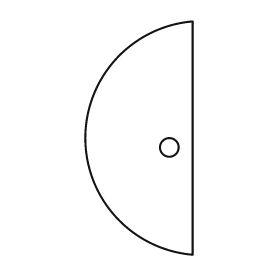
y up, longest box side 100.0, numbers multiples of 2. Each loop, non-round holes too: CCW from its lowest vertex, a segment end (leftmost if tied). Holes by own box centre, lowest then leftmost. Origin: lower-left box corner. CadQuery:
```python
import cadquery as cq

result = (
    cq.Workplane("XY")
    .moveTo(46.0, 0.0)
    .lineTo(46.0, 100.0)
    .threePointArc((0.0, 50.0), (46.0, 0.0))
    .close()
    .moveTo(36.0, 46.0)
    .circle(4.0)
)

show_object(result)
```